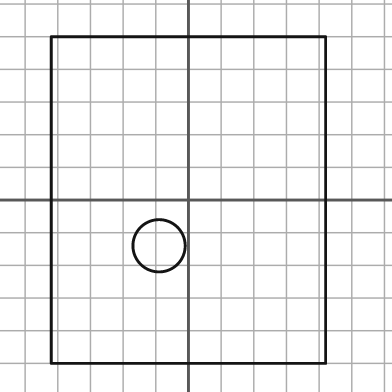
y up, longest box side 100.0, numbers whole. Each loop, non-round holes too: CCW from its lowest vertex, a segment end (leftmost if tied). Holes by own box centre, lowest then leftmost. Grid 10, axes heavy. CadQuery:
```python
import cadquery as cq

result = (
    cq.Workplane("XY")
    .moveTo(-42.0, -50.0)
    .lineTo(42.0, -50.0)
    .lineTo(42.0, 50.0)
    .lineTo(-42.0, 50.0)
    .close()
    .moveTo(-9.0, -14.0)
    .circle(8.0)
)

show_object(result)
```